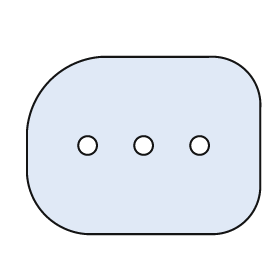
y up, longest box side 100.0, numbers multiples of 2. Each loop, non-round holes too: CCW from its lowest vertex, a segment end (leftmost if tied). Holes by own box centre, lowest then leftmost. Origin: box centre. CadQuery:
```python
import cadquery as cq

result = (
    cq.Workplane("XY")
    .moveTo(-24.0, -38.0)
    .lineTo(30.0, -38.0)
    .threePointArc((44.0, -32.0), (50.0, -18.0))
    .lineTo(50.0, 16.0)
    .threePointArc((44.0, 32.0), (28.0, 38.0))
    .lineTo(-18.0, 38.0)
    .threePointArc((-40.0, 28.0), (-50.0, 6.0))
    .lineTo(-50.0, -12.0)
    .threePointArc((-42.0, -30.0), (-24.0, -38.0))
    .close()
    .moveTo(-24.0, 0.0)
    .circle(4.0)
    .moveTo(0.0, 0.0)
    .circle(4.0)
    .moveTo(24.0, 0.0)
    .circle(4.0)
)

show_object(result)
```